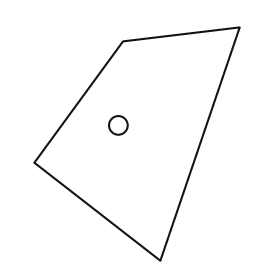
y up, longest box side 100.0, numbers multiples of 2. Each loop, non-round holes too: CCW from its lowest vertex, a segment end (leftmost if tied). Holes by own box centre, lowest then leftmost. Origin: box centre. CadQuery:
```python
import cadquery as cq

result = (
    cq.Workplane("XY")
    .moveTo(10.0, -50.0)
    .lineTo(44.0, 50.0)
    .lineTo(-6.0, 44.0)
    .lineTo(-44.0, -8.0)
    .close()
    .moveTo(-8.0, 8.0)
    .circle(4.0)
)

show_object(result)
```